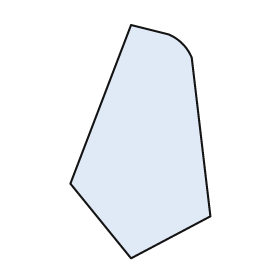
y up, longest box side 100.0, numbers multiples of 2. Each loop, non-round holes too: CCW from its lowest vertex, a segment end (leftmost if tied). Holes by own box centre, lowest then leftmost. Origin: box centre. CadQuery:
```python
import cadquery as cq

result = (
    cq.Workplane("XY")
    .moveTo(-4.0, -50.0)
    .lineTo(30.0, -32.0)
    .lineTo(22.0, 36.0)
    .threePointArc((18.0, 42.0), (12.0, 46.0))
    .lineTo(-4.0, 50.0)
    .lineTo(-30.0, -18.0)
    .close()
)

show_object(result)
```